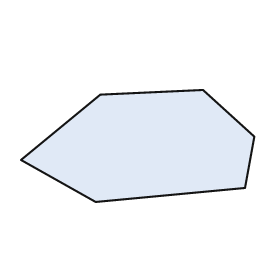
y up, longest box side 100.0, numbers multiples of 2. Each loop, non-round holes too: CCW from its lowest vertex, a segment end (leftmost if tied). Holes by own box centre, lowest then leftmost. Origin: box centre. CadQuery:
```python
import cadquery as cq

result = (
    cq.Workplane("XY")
    .moveTo(-18.0, -24.0)
    .lineTo(46.0, -18.0)
    .lineTo(50.0, 4.0)
    .lineTo(28.0, 24.0)
    .lineTo(-16.0, 22.0)
    .lineTo(-50.0, -6.0)
    .close()
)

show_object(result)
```